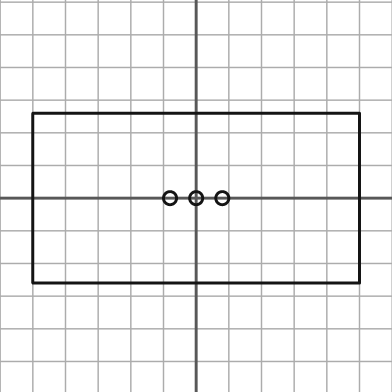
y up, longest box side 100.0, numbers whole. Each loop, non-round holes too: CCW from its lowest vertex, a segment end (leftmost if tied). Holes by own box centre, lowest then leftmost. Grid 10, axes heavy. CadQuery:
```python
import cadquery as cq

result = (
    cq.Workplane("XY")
    .moveTo(-50.0, -26.0)
    .lineTo(50.0, -26.0)
    .lineTo(50.0, 26.0)
    .lineTo(-50.0, 26.0)
    .close()
    .moveTo(-8.0, 0.0)
    .circle(2.0)
    .moveTo(0.0, 0.0)
    .circle(2.0)
    .moveTo(8.0, 0.0)
    .circle(2.0)
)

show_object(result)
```